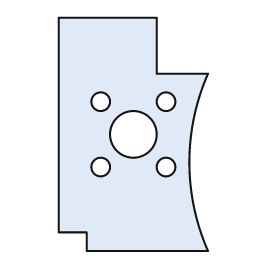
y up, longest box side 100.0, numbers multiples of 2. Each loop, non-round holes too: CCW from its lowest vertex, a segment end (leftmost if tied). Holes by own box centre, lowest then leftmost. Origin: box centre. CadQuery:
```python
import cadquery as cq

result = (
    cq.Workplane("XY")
    .moveTo(-20.0, -50.0)
    .lineTo(32.0, -50.0)
    .threePointArc((24.0, -12.0), (32.0, 26.0))
    .lineTo(10.0, 26.0)
    .lineTo(10.0, 50.0)
    .lineTo(-32.0, 50.0)
    .lineTo(-32.0, -42.0)
    .lineTo(-20.0, -42.0)
    .close()
    .moveTo(-14.0, -14.0)
    .circle(4.0)
    .moveTo(14.0, -14.0)
    .circle(4.0)
    .moveTo(0.0, 0.0)
    .circle(10.0)
    .moveTo(-14.0, 14.0)
    .circle(4.0)
    .moveTo(14.0, 14.0)
    .circle(4.0)
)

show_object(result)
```